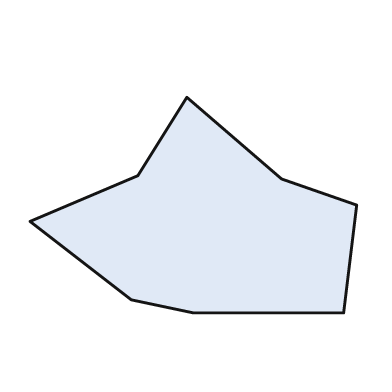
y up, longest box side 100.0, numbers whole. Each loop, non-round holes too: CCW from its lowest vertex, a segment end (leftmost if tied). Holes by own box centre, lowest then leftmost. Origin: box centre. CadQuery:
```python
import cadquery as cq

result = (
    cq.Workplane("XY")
    .moveTo(0.0, -33.0)
    .lineTo(46.0, -33.0)
    .lineTo(50.0, 0.0)
    .lineTo(27.0, 8.0)
    .lineTo(-2.0, 33.0)
    .lineTo(-17.0, 9.0)
    .lineTo(-50.0, -5.0)
    .lineTo(-19.0, -29.0)
    .close()
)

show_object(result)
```